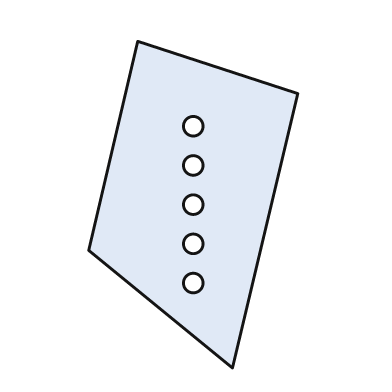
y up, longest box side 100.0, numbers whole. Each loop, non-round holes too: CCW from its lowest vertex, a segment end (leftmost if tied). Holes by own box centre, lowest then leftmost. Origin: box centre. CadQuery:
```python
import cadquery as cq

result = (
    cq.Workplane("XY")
    .moveTo(12.0, -50.0)
    .lineTo(32.0, 34.0)
    .lineTo(-17.0, 50.0)
    .lineTo(-32.0, -14.0)
    .close()
    .moveTo(0.0, -24.0)
    .circle(3.0)
    .moveTo(0.0, -12.0)
    .circle(3.0)
    .moveTo(0.0, 0.0)
    .circle(3.0)
    .moveTo(0.0, 12.0)
    .circle(3.0)
    .moveTo(0.0, 24.0)
    .circle(3.0)
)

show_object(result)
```